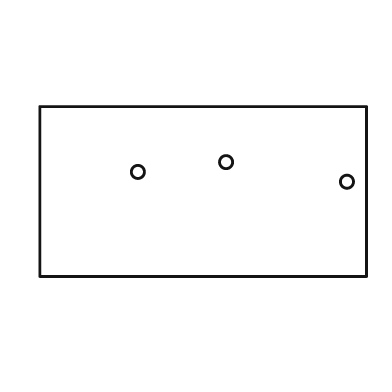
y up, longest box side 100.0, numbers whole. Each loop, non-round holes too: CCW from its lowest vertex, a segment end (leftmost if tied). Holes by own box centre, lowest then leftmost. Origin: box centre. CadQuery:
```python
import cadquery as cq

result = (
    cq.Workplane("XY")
    .moveTo(-50.0, -26.0)
    .lineTo(50.0, -26.0)
    .lineTo(50.0, 26.0)
    .lineTo(-50.0, 26.0)
    .close()
    .moveTo(44.0, 3.0)
    .circle(2.0)
    .moveTo(-20.0, 6.0)
    .circle(2.0)
    .moveTo(7.0, 9.0)
    .circle(2.0)
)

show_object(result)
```